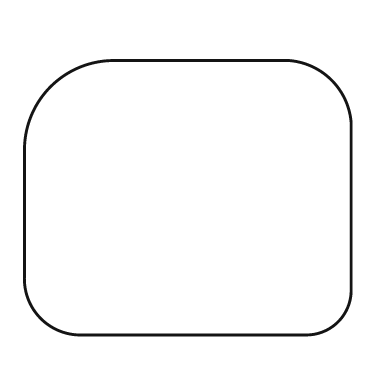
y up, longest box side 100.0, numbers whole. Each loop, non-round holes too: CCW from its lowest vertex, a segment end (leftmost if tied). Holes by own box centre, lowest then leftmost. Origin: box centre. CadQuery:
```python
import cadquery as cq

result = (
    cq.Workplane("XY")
    .moveTo(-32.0, -42.0)
    .lineTo(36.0, -42.0)
    .threePointArc((46.0, -38.0), (50.0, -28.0))
    .lineTo(50.0, 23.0)
    .threePointArc((44.0, 36.0), (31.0, 42.0))
    .lineTo(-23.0, 42.0)
    .threePointArc((-42.0, 34.0), (-50.0, 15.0))
    .lineTo(-50.0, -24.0)
    .threePointArc((-45.0, -37.0), (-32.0, -42.0))
    .close()
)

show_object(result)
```